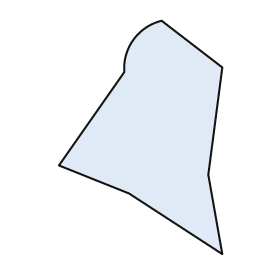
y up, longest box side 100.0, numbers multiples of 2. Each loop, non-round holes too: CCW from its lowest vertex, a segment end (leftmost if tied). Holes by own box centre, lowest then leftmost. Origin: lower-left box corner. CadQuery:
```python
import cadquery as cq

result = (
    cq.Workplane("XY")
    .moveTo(70.0, 0.0)
    .lineTo(64.0, 34.0)
    .lineTo(70.0, 80.0)
    .lineTo(44.0, 100.0)
    .threePointArc((32.0, 92.0), (28.0, 78.0))
    .lineTo(0.0, 38.0)
    .lineTo(30.0, 26.0)
    .close()
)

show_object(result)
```